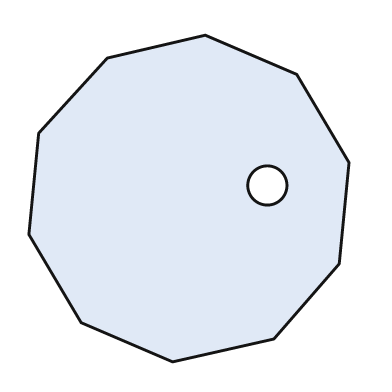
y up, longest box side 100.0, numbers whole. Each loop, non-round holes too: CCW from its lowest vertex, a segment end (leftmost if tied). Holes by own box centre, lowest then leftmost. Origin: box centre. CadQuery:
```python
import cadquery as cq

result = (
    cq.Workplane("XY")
    .moveTo(-5.0, -50.0)
    .lineTo(26.0, -43.0)
    .lineTo(46.0, -20.0)
    .lineTo(49.0, 11.0)
    .lineTo(33.0, 38.0)
    .lineTo(5.0, 50.0)
    .lineTo(-25.0, 43.0)
    .lineTo(-46.0, 20.0)
    .lineTo(-49.0, -11.0)
    .lineTo(-33.0, -38.0)
    .close()
    .moveTo(24.0, 4.0)
    .circle(6.0)
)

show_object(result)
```